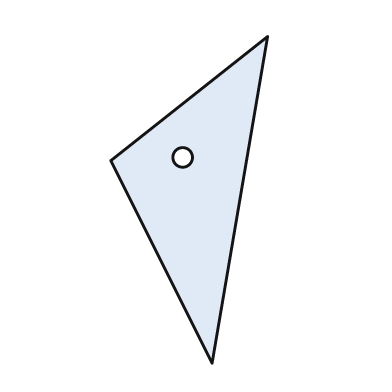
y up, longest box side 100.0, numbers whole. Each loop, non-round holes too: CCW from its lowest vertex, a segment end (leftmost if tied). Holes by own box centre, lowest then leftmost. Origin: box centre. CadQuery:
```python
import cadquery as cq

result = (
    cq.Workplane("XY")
    .moveTo(7.0, -50.0)
    .lineTo(24.0, 50.0)
    .lineTo(-24.0, 12.0)
    .close()
    .moveTo(-2.0, 13.0)
    .circle(3.0)
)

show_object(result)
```